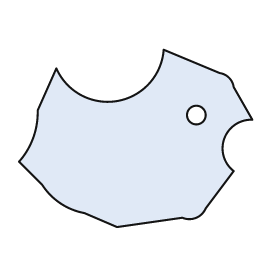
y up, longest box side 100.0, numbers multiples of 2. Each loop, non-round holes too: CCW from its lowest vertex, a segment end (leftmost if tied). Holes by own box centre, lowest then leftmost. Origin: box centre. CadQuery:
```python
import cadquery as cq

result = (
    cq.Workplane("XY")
    .moveTo(-8.0, -38.0)
    .lineTo(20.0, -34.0)
    .threePointArc((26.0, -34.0), (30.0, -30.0))
    .lineTo(42.0, -14.0)
    .threePointArc((38.0, 0.0), (50.0, 8.0))
    .lineTo(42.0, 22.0)
    .threePointArc((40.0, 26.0), (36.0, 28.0))
    .lineTo(12.0, 38.0)
    .threePointArc((-8.0, 16.0), (-34.0, 30.0))
    .lineTo(-42.0, 12.0)
    .threePointArc((-44.0, 0.0), (-50.0, -10.0))
    .lineTo(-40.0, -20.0)
    .threePointArc((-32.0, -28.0), (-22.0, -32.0))
    .close()
    .moveTo(26.0, 10.0)
    .circle(4.0)
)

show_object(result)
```